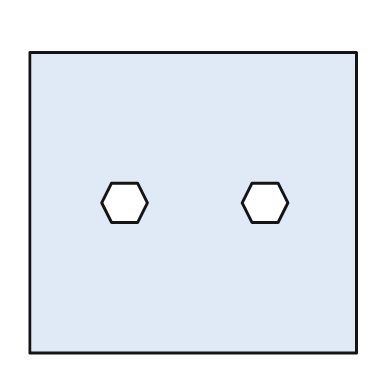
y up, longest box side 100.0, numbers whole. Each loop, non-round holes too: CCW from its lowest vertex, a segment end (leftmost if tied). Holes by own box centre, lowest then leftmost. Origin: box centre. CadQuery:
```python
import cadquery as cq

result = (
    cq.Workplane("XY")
    .moveTo(-50.0, -46.0)
    .lineTo(50.0, -46.0)
    .lineTo(50.0, 46.0)
    .lineTo(-50.0, 46.0)
    .close()
    .moveTo(-25.0, -6.0)
    .lineTo(-17.0, -6.0)
    .lineTo(-14.0, 0.0)
    .lineTo(-17.0, 6.0)
    .lineTo(-25.0, 6.0)
    .lineTo(-28.0, 0.0)
    .close()
    .moveTo(18.0, -6.0)
    .lineTo(26.0, -6.0)
    .lineTo(29.0, 0.0)
    .lineTo(26.0, 6.0)
    .lineTo(18.0, 6.0)
    .lineTo(15.0, 0.0)
    .close()
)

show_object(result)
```